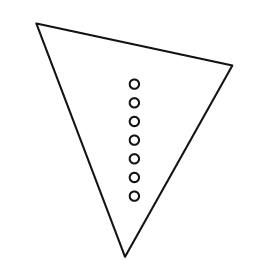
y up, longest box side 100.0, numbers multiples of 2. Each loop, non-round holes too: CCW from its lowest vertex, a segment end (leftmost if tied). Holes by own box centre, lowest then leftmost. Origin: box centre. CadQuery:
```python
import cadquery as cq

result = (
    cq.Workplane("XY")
    .moveTo(-4.0, -50.0)
    .lineTo(42.0, 32.0)
    .lineTo(-42.0, 50.0)
    .close()
    .moveTo(0.0, -24.0)
    .circle(2.0)
    .moveTo(0.0, -16.0)
    .circle(2.0)
    .moveTo(0.0, -8.0)
    .circle(2.0)
    .moveTo(0.0, 0.0)
    .circle(2.0)
    .moveTo(0.0, 8.0)
    .circle(2.0)
    .moveTo(0.0, 16.0)
    .circle(2.0)
    .moveTo(0.0, 24.0)
    .circle(2.0)
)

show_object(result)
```